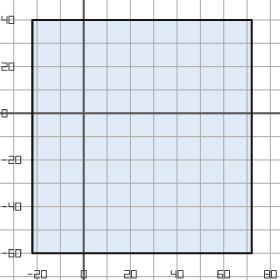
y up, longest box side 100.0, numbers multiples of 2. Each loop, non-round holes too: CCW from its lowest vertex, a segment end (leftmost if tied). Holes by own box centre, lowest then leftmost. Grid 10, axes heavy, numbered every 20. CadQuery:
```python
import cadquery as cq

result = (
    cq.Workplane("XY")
    .moveTo(-22.0, -60.0)
    .lineTo(72.0, -60.0)
    .lineTo(72.0, 40.0)
    .lineTo(-22.0, 40.0)
    .close()
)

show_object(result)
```